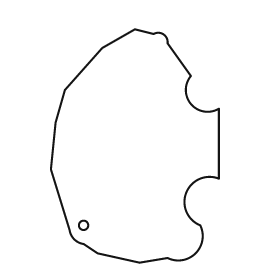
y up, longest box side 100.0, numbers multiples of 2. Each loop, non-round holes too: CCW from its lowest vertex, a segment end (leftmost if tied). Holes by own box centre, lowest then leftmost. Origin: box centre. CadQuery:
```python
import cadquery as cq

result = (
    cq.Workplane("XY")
    .moveTo(2.0, -50.0)
    .lineTo(14.0, -48.0)
    .threePointArc((26.0, -46.0), (28.0, -34.0))
    .threePointArc((22.0, -20.0), (36.0, -14.0))
    .lineTo(36.0, 16.0)
    .threePointArc((24.0, 18.0), (24.0, 30.0))
    .lineTo(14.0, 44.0)
    .threePointArc((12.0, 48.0), (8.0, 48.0))
    .lineTo(0.0, 50.0)
    .lineTo(-14.0, 42.0)
    .lineTo(-30.0, 24.0)
    .lineTo(-34.0, 10.0)
    .lineTo(-36.0, -10.0)
    .lineTo(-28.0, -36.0)
    .threePointArc((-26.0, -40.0), (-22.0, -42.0))
    .lineTo(-16.0, -46.0)
    .close()
    .moveTo(-22.0, -34.0)
    .circle(2.0)
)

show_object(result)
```